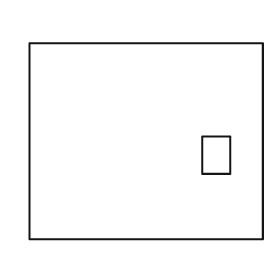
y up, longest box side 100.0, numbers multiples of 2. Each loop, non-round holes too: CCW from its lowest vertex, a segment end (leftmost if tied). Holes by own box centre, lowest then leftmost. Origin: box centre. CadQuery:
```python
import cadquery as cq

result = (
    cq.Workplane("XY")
    .moveTo(-50.0, -42.0)
    .lineTo(50.0, -42.0)
    .lineTo(50.0, 42.0)
    .lineTo(-50.0, 42.0)
    .close()
    .moveTo(24.0, -14.0)
    .lineTo(36.0, -14.0)
    .lineTo(36.0, 2.0)
    .lineTo(24.0, 2.0)
    .close()
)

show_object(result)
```